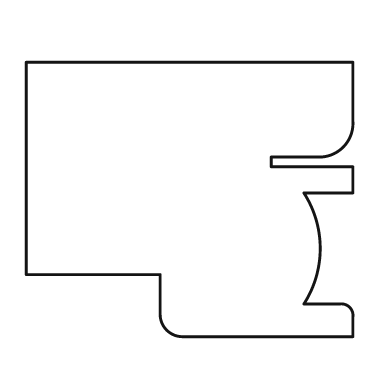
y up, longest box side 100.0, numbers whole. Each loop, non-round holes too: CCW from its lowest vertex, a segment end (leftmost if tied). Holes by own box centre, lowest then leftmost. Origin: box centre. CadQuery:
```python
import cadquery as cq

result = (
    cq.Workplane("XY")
    .moveTo(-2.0, -42.0)
    .lineTo(50.0, -42.0)
    .lineTo(50.0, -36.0)
    .threePointArc((49.0, -33.0), (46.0, -32.0))
    .lineTo(35.0, -32.0)
    .threePointArc((40.0, -15.0), (35.0, 2.0))
    .lineTo(50.0, 2.0)
    .lineTo(50.0, 10.0)
    .lineTo(25.0, 10.0)
    .lineTo(25.0, 13.0)
    .lineTo(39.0, 13.0)
    .threePointArc((47.0, 16.0), (50.0, 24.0))
    .lineTo(50.0, 42.0)
    .lineTo(-50.0, 42.0)
    .lineTo(-50.0, -23.0)
    .lineTo(-9.0, -23.0)
    .lineTo(-9.0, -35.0)
    .threePointArc((-7.0, -40.0), (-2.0, -42.0))
    .close()
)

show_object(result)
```